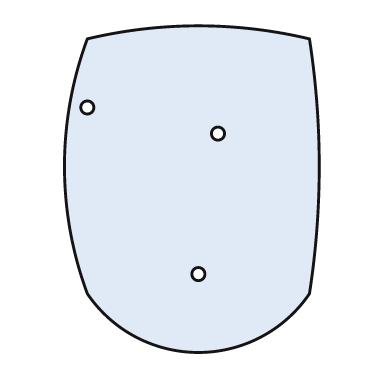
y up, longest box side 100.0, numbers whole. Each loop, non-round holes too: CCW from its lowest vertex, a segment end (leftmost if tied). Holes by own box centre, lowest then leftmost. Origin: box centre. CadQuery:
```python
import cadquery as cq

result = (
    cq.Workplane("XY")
    .moveTo(-32.0, -32.0)
    .threePointArc((2.0, -50.0), (36.0, -32.0))
    .threePointArc((39.0, 7.0), (36.0, 46.0))
    .threePointArc((2.0, 50.0), (-32.0, 46.0))
    .threePointArc((-39.0, 7.0), (-32.0, -32.0))
    .close()
    .moveTo(2.0, -26.0)
    .circle(2.0)
    .moveTo(8.0, 17.0)
    .circle(2.0)
    .moveTo(-32.0, 25.0)
    .circle(2.0)
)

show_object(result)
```